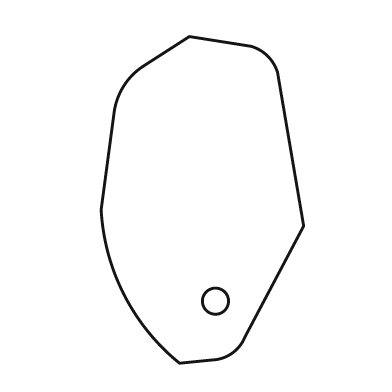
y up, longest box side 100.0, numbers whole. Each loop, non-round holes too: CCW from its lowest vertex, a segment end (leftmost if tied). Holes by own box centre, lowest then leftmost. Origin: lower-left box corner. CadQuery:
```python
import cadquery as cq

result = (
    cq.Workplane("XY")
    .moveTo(24.0, 0.0)
    .lineTo(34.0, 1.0)
    .threePointArc((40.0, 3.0), (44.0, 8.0))
    .lineTo(62.0, 42.0)
    .lineTo(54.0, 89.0)
    .threePointArc((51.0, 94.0), (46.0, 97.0))
    .lineTo(27.0, 100.0)
    .lineTo(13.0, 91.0)
    .threePointArc((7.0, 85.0), (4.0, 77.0))
    .lineTo(0.0, 47.0)
    .threePointArc((7.0, 21.0), (24.0, 0.0))
    .close()
    .moveTo(35.0, 19.0)
    .circle(4.0)
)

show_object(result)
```